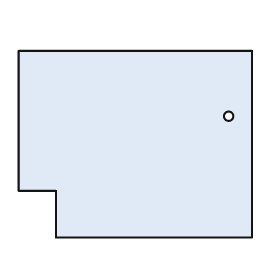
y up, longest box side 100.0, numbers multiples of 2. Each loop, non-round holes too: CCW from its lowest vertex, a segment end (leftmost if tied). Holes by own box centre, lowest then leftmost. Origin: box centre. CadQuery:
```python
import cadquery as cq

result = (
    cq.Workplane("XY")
    .moveTo(-34.0, -40.0)
    .lineTo(50.0, -40.0)
    .lineTo(50.0, 40.0)
    .lineTo(-50.0, 40.0)
    .lineTo(-50.0, -20.0)
    .lineTo(-34.0, -20.0)
    .close()
    .moveTo(40.0, 12.0)
    .circle(2.0)
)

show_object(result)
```